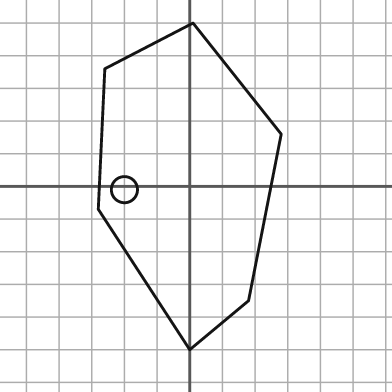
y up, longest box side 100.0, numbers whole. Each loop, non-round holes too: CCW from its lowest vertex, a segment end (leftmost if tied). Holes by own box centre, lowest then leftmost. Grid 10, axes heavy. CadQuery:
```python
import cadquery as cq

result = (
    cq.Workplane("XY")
    .moveTo(0.0, -50.0)
    .lineTo(18.0, -35.0)
    .lineTo(28.0, 16.0)
    .lineTo(1.0, 50.0)
    .lineTo(-26.0, 36.0)
    .lineTo(-28.0, -7.0)
    .close()
    .moveTo(-20.0, -1.0)
    .circle(4.0)
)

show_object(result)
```